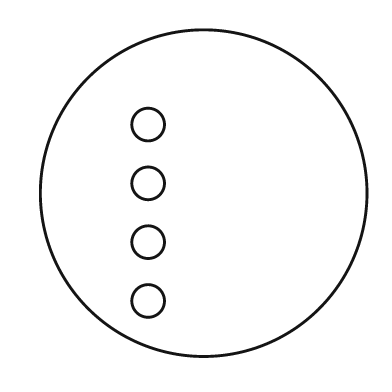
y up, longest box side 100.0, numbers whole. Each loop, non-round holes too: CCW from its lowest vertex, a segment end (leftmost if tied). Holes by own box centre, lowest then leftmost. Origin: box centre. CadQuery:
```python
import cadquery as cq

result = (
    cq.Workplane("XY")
    .moveTo(0.0, 0.0)
    .circle(50.0)
    .moveTo(-17.0, -33.0)
    .circle(5.0)
    .moveTo(-17.0, -15.0)
    .circle(5.0)
    .moveTo(-17.0, 3.0)
    .circle(5.0)
    .moveTo(-17.0, 21.0)
    .circle(5.0)
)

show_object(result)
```